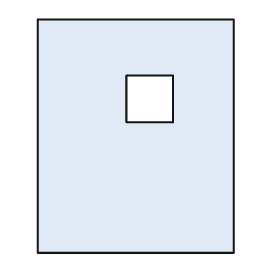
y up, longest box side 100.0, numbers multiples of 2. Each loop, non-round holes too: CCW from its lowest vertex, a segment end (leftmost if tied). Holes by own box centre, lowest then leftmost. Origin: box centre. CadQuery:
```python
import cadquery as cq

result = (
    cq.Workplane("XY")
    .moveTo(-42.0, -50.0)
    .lineTo(42.0, -50.0)
    .lineTo(42.0, 50.0)
    .lineTo(-42.0, 50.0)
    .close()
    .moveTo(-4.0, 6.0)
    .lineTo(16.0, 6.0)
    .lineTo(16.0, 26.0)
    .lineTo(-4.0, 26.0)
    .close()
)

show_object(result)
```